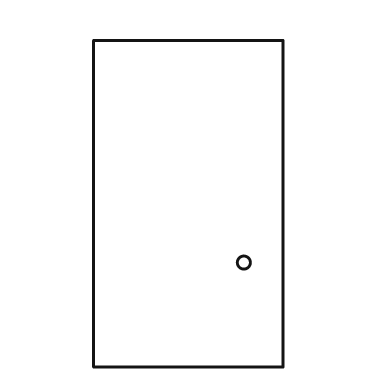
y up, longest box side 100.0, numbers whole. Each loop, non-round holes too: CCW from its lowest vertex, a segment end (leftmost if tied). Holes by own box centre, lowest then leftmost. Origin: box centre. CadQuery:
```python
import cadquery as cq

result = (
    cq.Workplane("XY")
    .moveTo(-29.0, -50.0)
    .lineTo(29.0, -50.0)
    .lineTo(29.0, 50.0)
    .lineTo(-29.0, 50.0)
    .close()
    .moveTo(17.0, -18.0)
    .circle(2.0)
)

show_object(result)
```